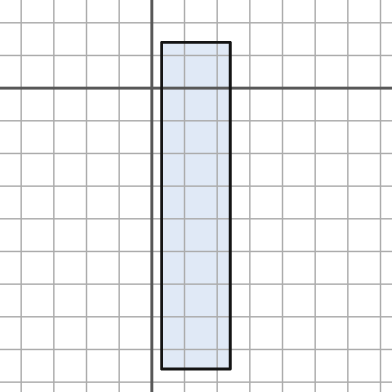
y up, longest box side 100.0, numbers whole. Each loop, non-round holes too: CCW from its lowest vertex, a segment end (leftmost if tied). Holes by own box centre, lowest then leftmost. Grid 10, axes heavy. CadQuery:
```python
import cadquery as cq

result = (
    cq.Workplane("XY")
    .moveTo(3.0, -86.0)
    .lineTo(24.0, -86.0)
    .lineTo(24.0, 14.0)
    .lineTo(3.0, 14.0)
    .close()
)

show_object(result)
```